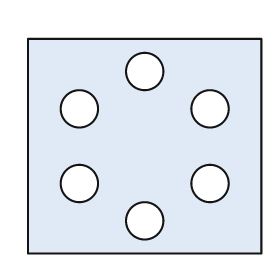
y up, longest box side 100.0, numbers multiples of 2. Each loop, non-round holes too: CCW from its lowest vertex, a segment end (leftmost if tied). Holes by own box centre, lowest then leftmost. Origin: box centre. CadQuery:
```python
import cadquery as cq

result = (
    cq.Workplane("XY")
    .moveTo(-50.0, -46.0)
    .lineTo(50.0, -46.0)
    .lineTo(50.0, 46.0)
    .lineTo(-50.0, 46.0)
    .close()
    .moveTo(0.0, -32.0)
    .circle(8.0)
    .moveTo(-28.0, -16.0)
    .circle(8.0)
    .moveTo(28.0, -16.0)
    .circle(8.0)
    .moveTo(-28.0, 16.0)
    .circle(8.0)
    .moveTo(28.0, 16.0)
    .circle(8.0)
    .moveTo(0.0, 32.0)
    .circle(8.0)
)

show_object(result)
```